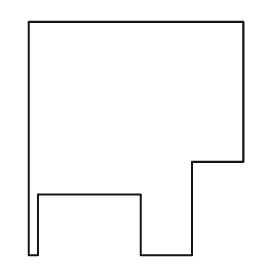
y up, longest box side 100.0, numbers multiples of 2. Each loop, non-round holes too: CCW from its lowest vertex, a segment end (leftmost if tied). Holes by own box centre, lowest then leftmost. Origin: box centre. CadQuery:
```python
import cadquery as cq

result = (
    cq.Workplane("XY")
    .moveTo(-46.0, -50.0)
    .lineTo(-42.0, -50.0)
    .lineTo(-42.0, -24.0)
    .lineTo(2.0, -24.0)
    .lineTo(2.0, -50.0)
    .lineTo(24.0, -50.0)
    .lineTo(24.0, -10.0)
    .lineTo(46.0, -10.0)
    .lineTo(46.0, 50.0)
    .lineTo(-46.0, 50.0)
    .close()
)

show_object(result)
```